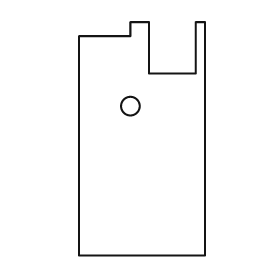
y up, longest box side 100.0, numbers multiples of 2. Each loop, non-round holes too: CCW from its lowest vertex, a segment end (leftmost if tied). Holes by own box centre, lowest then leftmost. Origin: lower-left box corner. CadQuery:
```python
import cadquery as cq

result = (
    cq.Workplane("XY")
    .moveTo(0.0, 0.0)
    .lineTo(54.0, 0.0)
    .lineTo(54.0, 100.0)
    .lineTo(50.0, 100.0)
    .lineTo(50.0, 78.0)
    .lineTo(30.0, 78.0)
    .lineTo(30.0, 100.0)
    .lineTo(22.0, 100.0)
    .lineTo(22.0, 94.0)
    .lineTo(0.0, 94.0)
    .close()
    .moveTo(22.0, 64.0)
    .circle(4.0)
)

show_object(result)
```